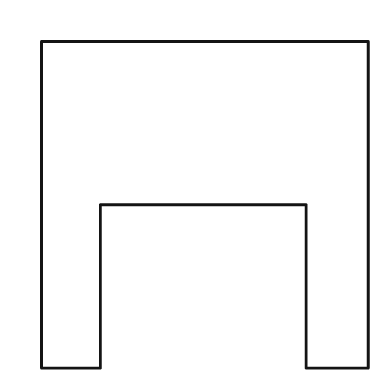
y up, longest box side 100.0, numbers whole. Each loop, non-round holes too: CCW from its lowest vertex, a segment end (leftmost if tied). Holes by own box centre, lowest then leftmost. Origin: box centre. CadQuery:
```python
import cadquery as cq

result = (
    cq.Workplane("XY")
    .moveTo(-50.0, -50.0)
    .lineTo(-32.0, -50.0)
    .lineTo(-32.0, 0.0)
    .lineTo(31.0, 0.0)
    .lineTo(31.0, -50.0)
    .lineTo(50.0, -50.0)
    .lineTo(50.0, 50.0)
    .lineTo(-50.0, 50.0)
    .close()
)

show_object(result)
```